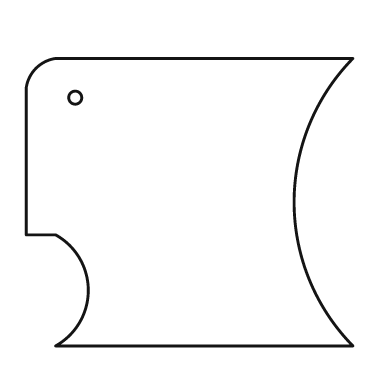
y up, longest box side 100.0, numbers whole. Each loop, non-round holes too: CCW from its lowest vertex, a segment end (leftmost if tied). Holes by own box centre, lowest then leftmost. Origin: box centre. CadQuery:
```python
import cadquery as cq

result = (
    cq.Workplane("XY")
    .moveTo(-41.0, -44.0)
    .lineTo(50.0, -44.0)
    .threePointArc((32.0, 0.0), (50.0, 44.0))
    .lineTo(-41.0, 44.0)
    .threePointArc((-47.0, 41.0), (-50.0, 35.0))
    .lineTo(-50.0, -10.0)
    .lineTo(-41.0, -10.0)
    .threePointArc((-31.0, -27.0), (-41.0, -44.0))
    .close()
    .moveTo(-35.0, 32.0)
    .circle(2.0)
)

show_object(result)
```